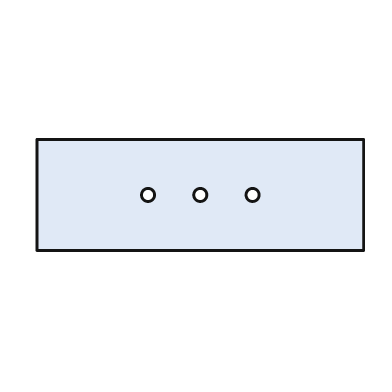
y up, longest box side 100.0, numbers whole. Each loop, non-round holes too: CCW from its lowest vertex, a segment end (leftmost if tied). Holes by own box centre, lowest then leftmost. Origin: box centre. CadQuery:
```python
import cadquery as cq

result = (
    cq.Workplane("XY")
    .moveTo(-50.0, -17.0)
    .lineTo(50.0, -17.0)
    .lineTo(50.0, 17.0)
    .lineTo(-50.0, 17.0)
    .close()
    .moveTo(-16.0, 0.0)
    .circle(2.0)
    .moveTo(0.0, 0.0)
    .circle(2.0)
    .moveTo(16.0, 0.0)
    .circle(2.0)
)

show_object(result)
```